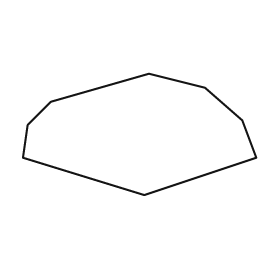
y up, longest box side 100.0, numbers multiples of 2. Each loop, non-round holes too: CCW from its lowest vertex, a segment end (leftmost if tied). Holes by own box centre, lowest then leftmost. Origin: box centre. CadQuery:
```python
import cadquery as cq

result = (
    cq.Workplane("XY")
    .moveTo(2.0, -26.0)
    .lineTo(50.0, -10.0)
    .lineTo(44.0, 6.0)
    .lineTo(28.0, 20.0)
    .lineTo(4.0, 26.0)
    .lineTo(-38.0, 14.0)
    .lineTo(-48.0, 4.0)
    .lineTo(-50.0, -10.0)
    .close()
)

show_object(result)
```